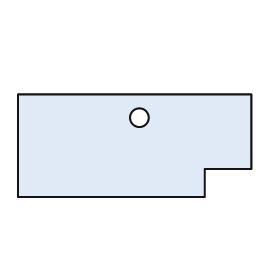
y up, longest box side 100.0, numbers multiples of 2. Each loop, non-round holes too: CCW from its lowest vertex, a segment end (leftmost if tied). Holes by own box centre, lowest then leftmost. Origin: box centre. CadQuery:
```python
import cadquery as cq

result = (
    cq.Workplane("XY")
    .moveTo(-50.0, -22.0)
    .lineTo(30.0, -22.0)
    .lineTo(30.0, -10.0)
    .lineTo(50.0, -10.0)
    .lineTo(50.0, 22.0)
    .lineTo(-50.0, 22.0)
    .close()
    .moveTo(2.0, 12.0)
    .circle(4.0)
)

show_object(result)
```